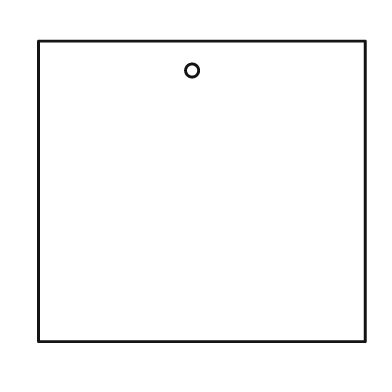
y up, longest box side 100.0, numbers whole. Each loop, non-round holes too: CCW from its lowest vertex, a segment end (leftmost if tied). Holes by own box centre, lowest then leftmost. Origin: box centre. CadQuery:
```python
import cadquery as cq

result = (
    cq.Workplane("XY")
    .moveTo(-50.0, -46.0)
    .lineTo(50.0, -46.0)
    .lineTo(50.0, 46.0)
    .lineTo(-50.0, 46.0)
    .close()
    .moveTo(-3.0, 37.0)
    .circle(2.0)
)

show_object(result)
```